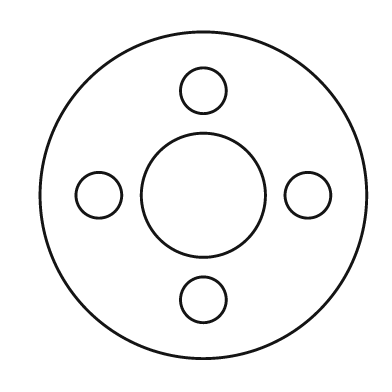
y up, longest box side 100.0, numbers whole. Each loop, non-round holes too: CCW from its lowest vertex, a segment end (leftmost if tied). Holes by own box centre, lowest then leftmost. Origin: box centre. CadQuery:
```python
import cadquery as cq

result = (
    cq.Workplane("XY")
    .moveTo(0.0, 0.0)
    .circle(50.0)
    .moveTo(0.0, -32.0)
    .circle(7.0)
    .moveTo(-32.0, 0.0)
    .circle(7.0)
    .moveTo(0.0, 0.0)
    .circle(19.0)
    .moveTo(32.0, 0.0)
    .circle(7.0)
    .moveTo(0.0, 32.0)
    .circle(7.0)
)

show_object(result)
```